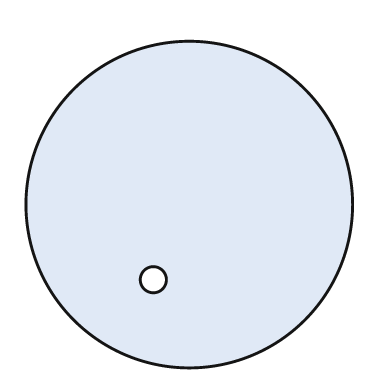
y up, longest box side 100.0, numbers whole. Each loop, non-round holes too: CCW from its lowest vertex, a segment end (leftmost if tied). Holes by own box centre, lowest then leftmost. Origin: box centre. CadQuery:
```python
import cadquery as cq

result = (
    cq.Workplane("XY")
    .moveTo(0.0, 0.0)
    .circle(50.0)
    .moveTo(-11.0, -23.0)
    .circle(4.0)
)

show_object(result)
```